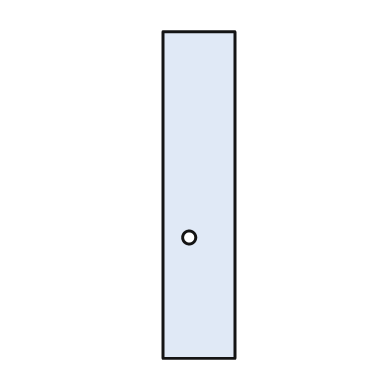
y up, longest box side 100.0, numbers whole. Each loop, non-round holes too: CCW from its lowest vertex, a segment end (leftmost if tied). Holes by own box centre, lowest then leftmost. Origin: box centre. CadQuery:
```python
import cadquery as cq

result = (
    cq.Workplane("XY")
    .moveTo(-11.0, -50.0)
    .lineTo(11.0, -50.0)
    .lineTo(11.0, 50.0)
    .lineTo(-11.0, 50.0)
    .close()
    .moveTo(-3.0, -13.0)
    .circle(2.0)
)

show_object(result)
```